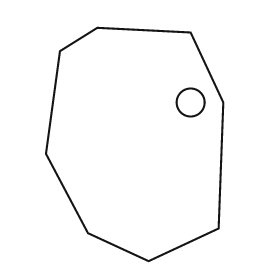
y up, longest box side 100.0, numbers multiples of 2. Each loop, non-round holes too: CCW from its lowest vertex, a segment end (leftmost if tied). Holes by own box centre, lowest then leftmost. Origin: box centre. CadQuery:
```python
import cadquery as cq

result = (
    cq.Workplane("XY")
    .moveTo(6.0, -50.0)
    .lineTo(36.0, -36.0)
    .lineTo(38.0, 18.0)
    .lineTo(24.0, 48.0)
    .lineTo(-16.0, 50.0)
    .lineTo(-32.0, 40.0)
    .lineTo(-38.0, -4.0)
    .lineTo(-20.0, -38.0)
    .close()
    .moveTo(24.0, 18.0)
    .circle(6.0)
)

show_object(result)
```